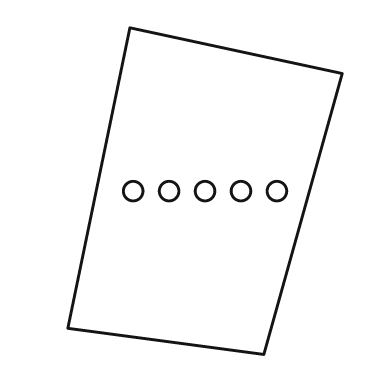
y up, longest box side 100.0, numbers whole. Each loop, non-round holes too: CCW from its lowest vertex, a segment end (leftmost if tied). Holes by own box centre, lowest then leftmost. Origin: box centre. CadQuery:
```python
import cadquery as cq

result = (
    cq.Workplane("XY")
    .moveTo(18.0, -50.0)
    .lineTo(42.0, 36.0)
    .lineTo(-23.0, 50.0)
    .lineTo(-42.0, -42.0)
    .close()
    .moveTo(-22.0, 0.0)
    .circle(3.0)
    .moveTo(-11.0, 0.0)
    .circle(3.0)
    .moveTo(0.0, 0.0)
    .circle(3.0)
    .moveTo(11.0, 0.0)
    .circle(3.0)
    .moveTo(22.0, 0.0)
    .circle(3.0)
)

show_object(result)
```